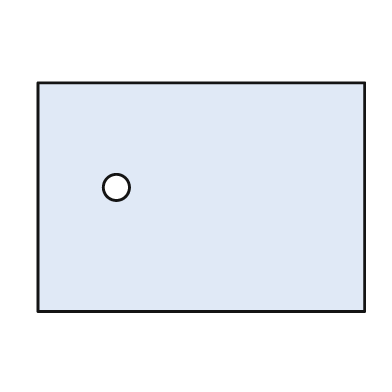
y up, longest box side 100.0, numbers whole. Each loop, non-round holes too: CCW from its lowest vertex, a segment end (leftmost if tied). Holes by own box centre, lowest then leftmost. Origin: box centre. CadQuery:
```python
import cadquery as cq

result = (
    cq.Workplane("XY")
    .moveTo(-50.0, -35.0)
    .lineTo(50.0, -35.0)
    .lineTo(50.0, 35.0)
    .lineTo(-50.0, 35.0)
    .close()
    .moveTo(-26.0, 3.0)
    .circle(4.0)
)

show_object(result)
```